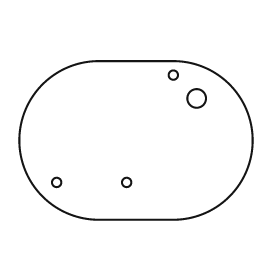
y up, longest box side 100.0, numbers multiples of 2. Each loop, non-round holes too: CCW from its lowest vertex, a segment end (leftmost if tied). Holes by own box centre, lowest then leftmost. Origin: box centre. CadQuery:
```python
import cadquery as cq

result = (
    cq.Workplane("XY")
    .moveTo(-16.0, -34.0)
    .lineTo(16.0, -34.0)
    .threePointArc((50.0, 0.0), (16.0, 34.0))
    .lineTo(-16.0, 34.0)
    .threePointArc((-50.0, 0.0), (-16.0, -34.0))
    .close()
    .moveTo(-34.0, -18.0)
    .circle(2.0)
    .moveTo(-4.0, -18.0)
    .circle(2.0)
    .moveTo(26.0, 18.0)
    .circle(4.0)
    .moveTo(16.0, 28.0)
    .circle(2.0)
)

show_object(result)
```